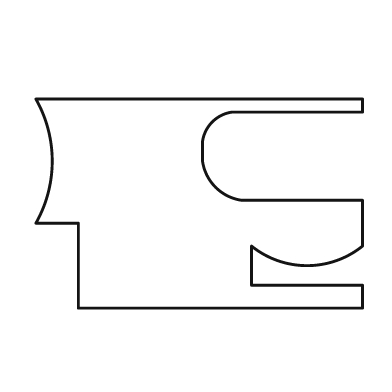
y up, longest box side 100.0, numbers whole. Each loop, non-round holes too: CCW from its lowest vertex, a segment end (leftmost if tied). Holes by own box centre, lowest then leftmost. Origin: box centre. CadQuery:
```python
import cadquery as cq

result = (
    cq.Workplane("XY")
    .moveTo(-37.0, -32.0)
    .lineTo(50.0, -32.0)
    .lineTo(50.0, -25.0)
    .lineTo(16.0, -25.0)
    .lineTo(16.0, -13.0)
    .threePointArc((33.0, -19.0), (50.0, -13.0))
    .lineTo(50.0, 1.0)
    .lineTo(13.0, 1.0)
    .threePointArc((5.0, 5.0), (1.0, 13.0))
    .lineTo(1.0, 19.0)
    .threePointArc((4.0, 25.0), (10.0, 28.0))
    .lineTo(50.0, 28.0)
    .lineTo(50.0, 32.0)
    .lineTo(-50.0, 32.0)
    .threePointArc((-45.0, 13.0), (-50.0, -6.0))
    .lineTo(-37.0, -6.0)
    .close()
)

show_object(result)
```